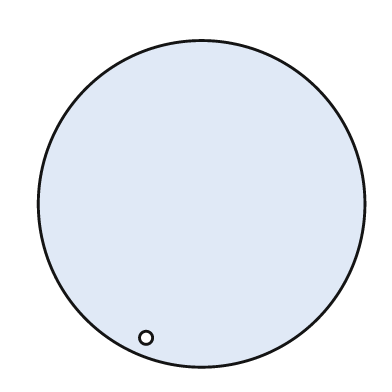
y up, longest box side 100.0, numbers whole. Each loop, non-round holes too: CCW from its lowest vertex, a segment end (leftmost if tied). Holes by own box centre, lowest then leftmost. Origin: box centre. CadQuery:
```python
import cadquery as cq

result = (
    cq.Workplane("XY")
    .moveTo(0.0, 0.0)
    .circle(50.0)
    .moveTo(-17.0, -41.0)
    .circle(2.0)
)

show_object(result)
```